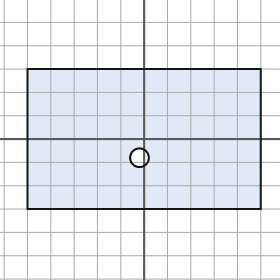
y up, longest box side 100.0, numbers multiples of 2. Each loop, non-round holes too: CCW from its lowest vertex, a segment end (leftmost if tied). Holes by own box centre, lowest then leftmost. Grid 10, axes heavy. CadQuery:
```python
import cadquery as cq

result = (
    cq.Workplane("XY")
    .moveTo(-50.0, -30.0)
    .lineTo(50.0, -30.0)
    .lineTo(50.0, 30.0)
    .lineTo(-50.0, 30.0)
    .close()
    .moveTo(-2.0, -8.0)
    .circle(4.0)
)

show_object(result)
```